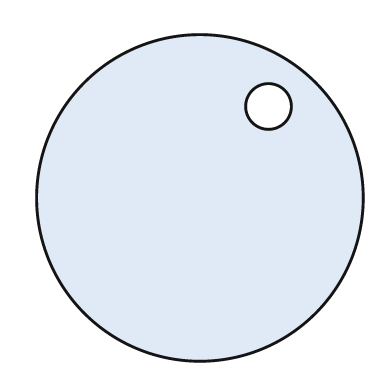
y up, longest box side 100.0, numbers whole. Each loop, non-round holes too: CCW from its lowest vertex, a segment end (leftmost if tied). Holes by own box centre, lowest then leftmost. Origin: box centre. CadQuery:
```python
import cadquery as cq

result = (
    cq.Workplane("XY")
    .moveTo(0.0, 0.0)
    .circle(50.0)
    .moveTo(21.0, 28.0)
    .circle(7.0)
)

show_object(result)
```